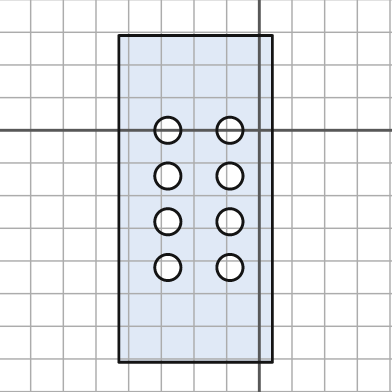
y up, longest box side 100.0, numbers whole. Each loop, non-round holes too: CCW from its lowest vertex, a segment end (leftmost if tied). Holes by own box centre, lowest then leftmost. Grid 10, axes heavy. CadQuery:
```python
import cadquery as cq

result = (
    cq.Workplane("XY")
    .moveTo(-43.0, -71.0)
    .lineTo(4.0, -71.0)
    .lineTo(4.0, 29.0)
    .lineTo(-43.0, 29.0)
    .close()
    .moveTo(-28.0, -42.0)
    .circle(4.0)
    .moveTo(-9.0, -42.0)
    .circle(4.0)
    .moveTo(-28.0, -28.0)
    .circle(4.0)
    .moveTo(-9.0, -28.0)
    .circle(4.0)
    .moveTo(-28.0, -14.0)
    .circle(4.0)
    .moveTo(-9.0, -14.0)
    .circle(4.0)
    .moveTo(-28.0, 0.0)
    .circle(4.0)
    .moveTo(-9.0, 0.0)
    .circle(4.0)
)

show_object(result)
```